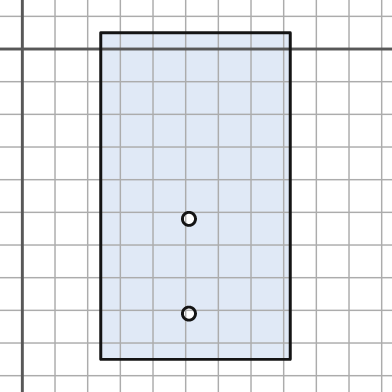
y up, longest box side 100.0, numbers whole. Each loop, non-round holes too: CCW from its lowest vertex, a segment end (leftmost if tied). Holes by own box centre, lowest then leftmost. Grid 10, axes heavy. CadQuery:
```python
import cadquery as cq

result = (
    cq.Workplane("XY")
    .moveTo(24.0, -95.0)
    .lineTo(82.0, -95.0)
    .lineTo(82.0, 5.0)
    .lineTo(24.0, 5.0)
    .close()
    .moveTo(51.0, -81.0)
    .circle(2.0)
    .moveTo(51.0, -52.0)
    .circle(2.0)
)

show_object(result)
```